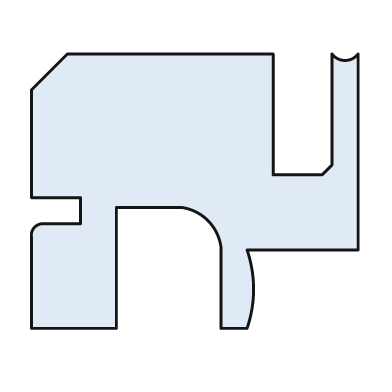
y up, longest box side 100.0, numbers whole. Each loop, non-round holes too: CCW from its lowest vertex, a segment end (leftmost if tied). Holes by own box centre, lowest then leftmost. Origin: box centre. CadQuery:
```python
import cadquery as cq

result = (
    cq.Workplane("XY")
    .moveTo(-50.0, -42.0)
    .lineTo(-24.0, -42.0)
    .lineTo(-24.0, -5.0)
    .lineTo(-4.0, -5.0)
    .threePointArc((4.0, -9.0), (8.0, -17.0))
    .lineTo(8.0, -42.0)
    .lineTo(16.0, -42.0)
    .threePointArc((18.0, -30.0), (16.0, -18.0))
    .lineTo(50.0, -18.0)
    .lineTo(50.0, 42.0)
    .threePointArc((46.0, 40.0), (42.0, 42.0))
    .lineTo(42.0, 8.0)
    .lineTo(39.0, 5.0)
    .lineTo(24.0, 5.0)
    .lineTo(24.0, 42.0)
    .lineTo(-39.0, 42.0)
    .lineTo(-50.0, 31.0)
    .lineTo(-50.0, -2.0)
    .lineTo(-35.0, -2.0)
    .lineTo(-35.0, -10.0)
    .lineTo(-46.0, -10.0)
    .threePointArc((-49.0, -11.0), (-50.0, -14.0))
    .close()
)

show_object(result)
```